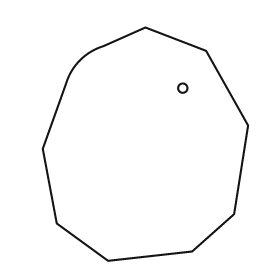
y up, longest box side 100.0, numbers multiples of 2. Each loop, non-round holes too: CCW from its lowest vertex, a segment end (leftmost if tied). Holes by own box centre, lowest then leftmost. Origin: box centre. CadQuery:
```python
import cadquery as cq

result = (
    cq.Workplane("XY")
    .moveTo(-16.0, -50.0)
    .lineTo(20.0, -46.0)
    .lineTo(38.0, -30.0)
    .lineTo(44.0, 8.0)
    .lineTo(26.0, 40.0)
    .lineTo(0.0, 50.0)
    .lineTo(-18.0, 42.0)
    .threePointArc((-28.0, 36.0), (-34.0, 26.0))
    .lineTo(-44.0, -2.0)
    .lineTo(-38.0, -34.0)
    .close()
    .moveTo(16.0, 24.0)
    .circle(2.0)
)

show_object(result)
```